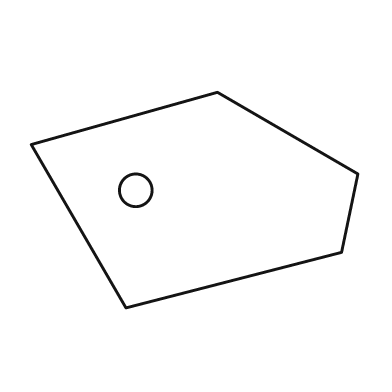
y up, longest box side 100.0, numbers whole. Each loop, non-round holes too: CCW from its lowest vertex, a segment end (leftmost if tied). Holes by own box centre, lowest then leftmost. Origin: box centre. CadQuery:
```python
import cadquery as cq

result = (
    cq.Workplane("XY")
    .moveTo(-21.0, -33.0)
    .lineTo(45.0, -16.0)
    .lineTo(50.0, 8.0)
    .lineTo(7.0, 33.0)
    .lineTo(-50.0, 17.0)
    .close()
    .moveTo(-18.0, 3.0)
    .circle(5.0)
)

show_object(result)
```